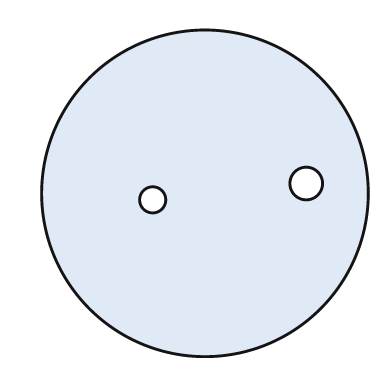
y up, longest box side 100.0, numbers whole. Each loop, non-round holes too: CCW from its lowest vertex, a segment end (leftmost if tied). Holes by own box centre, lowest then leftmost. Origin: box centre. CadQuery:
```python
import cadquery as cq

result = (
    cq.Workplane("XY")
    .moveTo(0.0, 0.0)
    .circle(50.0)
    .moveTo(-16.0, -2.0)
    .circle(4.0)
    .moveTo(31.0, 3.0)
    .circle(5.0)
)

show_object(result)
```